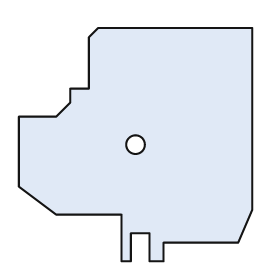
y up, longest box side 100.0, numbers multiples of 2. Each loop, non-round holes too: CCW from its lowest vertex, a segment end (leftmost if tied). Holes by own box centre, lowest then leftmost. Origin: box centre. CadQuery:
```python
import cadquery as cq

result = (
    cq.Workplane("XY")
    .moveTo(-6.0, -50.0)
    .lineTo(-2.0, -50.0)
    .lineTo(-2.0, -38.0)
    .lineTo(6.0, -38.0)
    .lineTo(6.0, -50.0)
    .lineTo(12.0, -50.0)
    .lineTo(12.0, -42.0)
    .lineTo(44.0, -42.0)
    .lineTo(50.0, -28.0)
    .lineTo(50.0, 50.0)
    .lineTo(-16.0, 50.0)
    .lineTo(-20.0, 46.0)
    .lineTo(-20.0, 24.0)
    .lineTo(-28.0, 24.0)
    .lineTo(-28.0, 18.0)
    .lineTo(-34.0, 12.0)
    .lineTo(-50.0, 12.0)
    .lineTo(-50.0, -18.0)
    .lineTo(-34.0, -30.0)
    .lineTo(-6.0, -30.0)
    .close()
    .moveTo(0.0, 0.0)
    .circle(4.0)
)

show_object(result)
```